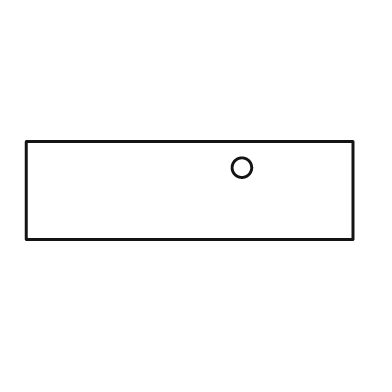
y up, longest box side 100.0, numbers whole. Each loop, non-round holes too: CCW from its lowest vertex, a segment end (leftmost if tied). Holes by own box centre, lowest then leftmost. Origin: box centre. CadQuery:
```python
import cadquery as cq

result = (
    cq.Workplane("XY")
    .moveTo(-50.0, -15.0)
    .lineTo(50.0, -15.0)
    .lineTo(50.0, 15.0)
    .lineTo(-50.0, 15.0)
    .close()
    .moveTo(16.0, 7.0)
    .circle(3.0)
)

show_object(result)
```